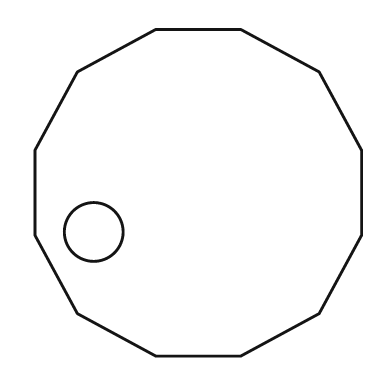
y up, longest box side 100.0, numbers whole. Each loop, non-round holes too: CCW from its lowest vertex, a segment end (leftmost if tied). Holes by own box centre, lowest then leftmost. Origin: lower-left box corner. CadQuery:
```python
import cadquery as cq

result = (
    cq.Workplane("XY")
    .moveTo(37.0, 0.0)
    .lineTo(63.0, 0.0)
    .lineTo(87.0, 13.0)
    .lineTo(100.0, 37.0)
    .lineTo(100.0, 63.0)
    .lineTo(87.0, 87.0)
    .lineTo(63.0, 100.0)
    .lineTo(37.0, 100.0)
    .lineTo(13.0, 87.0)
    .lineTo(0.0, 63.0)
    .lineTo(0.0, 37.0)
    .lineTo(13.0, 13.0)
    .close()
    .moveTo(18.0, 38.0)
    .circle(9.0)
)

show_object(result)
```